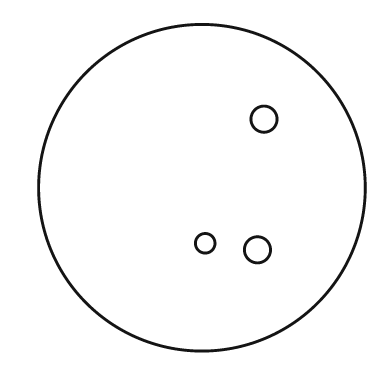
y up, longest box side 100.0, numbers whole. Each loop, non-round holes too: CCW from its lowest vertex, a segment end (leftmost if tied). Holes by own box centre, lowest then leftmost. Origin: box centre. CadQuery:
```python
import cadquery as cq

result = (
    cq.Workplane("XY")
    .moveTo(0.0, 0.0)
    .circle(50.0)
    .moveTo(17.0, -19.0)
    .circle(4.0)
    .moveTo(1.0, -17.0)
    .circle(3.0)
    .moveTo(19.0, 21.0)
    .circle(4.0)
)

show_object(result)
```